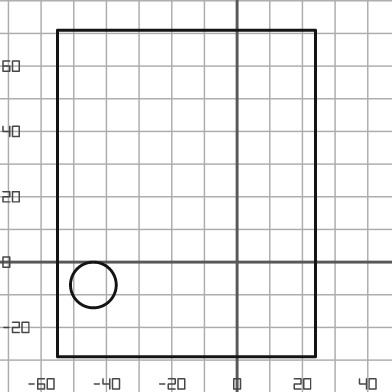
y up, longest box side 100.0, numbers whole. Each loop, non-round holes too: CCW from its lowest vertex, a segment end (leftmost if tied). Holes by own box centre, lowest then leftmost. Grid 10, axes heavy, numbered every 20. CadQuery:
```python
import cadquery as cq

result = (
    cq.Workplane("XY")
    .moveTo(-55.0, -29.0)
    .lineTo(24.0, -29.0)
    .lineTo(24.0, 71.0)
    .lineTo(-55.0, 71.0)
    .close()
    .moveTo(-44.0, -7.0)
    .circle(7.0)
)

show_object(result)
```